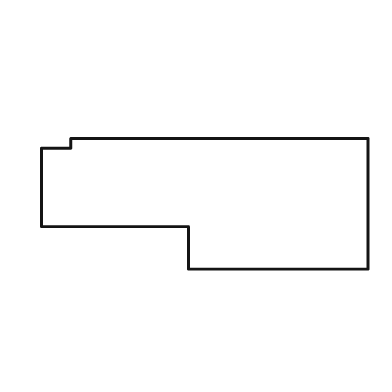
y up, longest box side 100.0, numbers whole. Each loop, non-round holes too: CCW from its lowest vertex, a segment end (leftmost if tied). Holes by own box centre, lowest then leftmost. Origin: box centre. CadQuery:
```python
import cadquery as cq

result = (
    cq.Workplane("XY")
    .moveTo(-5.0, -20.0)
    .lineTo(50.0, -20.0)
    .lineTo(50.0, 20.0)
    .lineTo(-41.0, 20.0)
    .lineTo(-41.0, 17.0)
    .lineTo(-50.0, 17.0)
    .lineTo(-50.0, -7.0)
    .lineTo(-5.0, -7.0)
    .close()
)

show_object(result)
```